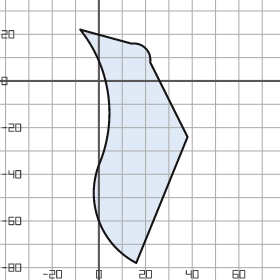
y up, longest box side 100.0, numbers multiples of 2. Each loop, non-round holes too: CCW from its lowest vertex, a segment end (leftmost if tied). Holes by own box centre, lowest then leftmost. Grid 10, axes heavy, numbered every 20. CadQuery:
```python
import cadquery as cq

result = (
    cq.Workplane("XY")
    .moveTo(16.0, -78.0)
    .lineTo(38.0, -24.0)
    .lineTo(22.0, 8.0)
    .threePointArc((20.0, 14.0), (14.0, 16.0))
    .lineTo(-8.0, 22.0)
    .threePointArc((4.0, -6.0), (0.0, -36.0))
    .threePointArc((0.0, -60.0), (16.0, -78.0))
    .close()
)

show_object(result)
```